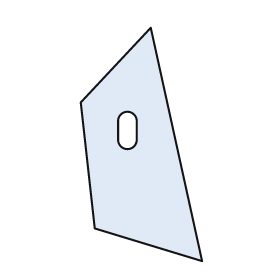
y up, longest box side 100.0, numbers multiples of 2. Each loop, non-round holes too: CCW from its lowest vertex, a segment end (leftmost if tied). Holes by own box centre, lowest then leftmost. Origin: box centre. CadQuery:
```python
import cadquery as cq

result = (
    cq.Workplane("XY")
    .moveTo(26.0, -50.0)
    .lineTo(4.0, 50.0)
    .lineTo(-26.0, 18.0)
    .lineTo(-20.0, -36.0)
    .close()
    .moveTo(-10.0, 2.0)
    .threePointArc((-6.0, -2.0), (-2.0, 2.0))
    .lineTo(-2.0, 10.0)
    .threePointArc((-6.0, 14.0), (-10.0, 10.0))
    .close()
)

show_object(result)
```